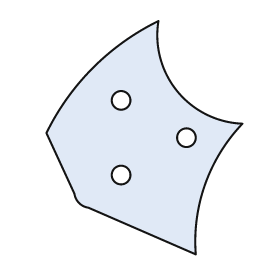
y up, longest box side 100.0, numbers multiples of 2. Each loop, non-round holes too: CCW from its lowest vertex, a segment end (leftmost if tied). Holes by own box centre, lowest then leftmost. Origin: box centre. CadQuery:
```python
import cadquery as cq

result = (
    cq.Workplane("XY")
    .moveTo(22.0, -50.0)
    .threePointArc((26.0, -20.0), (42.0, 6.0))
    .threePointArc((14.0, 20.0), (6.0, 50.0))
    .threePointArc((-22.0, 30.0), (-42.0, 2.0))
    .lineTo(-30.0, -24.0)
    .threePointArc((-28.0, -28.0), (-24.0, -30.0))
    .close()
    .moveTo(-10.0, -16.0)
    .circle(4.0)
    .moveTo(18.0, 0.0)
    .circle(4.0)
    .moveTo(-10.0, 16.0)
    .circle(4.0)
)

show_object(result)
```